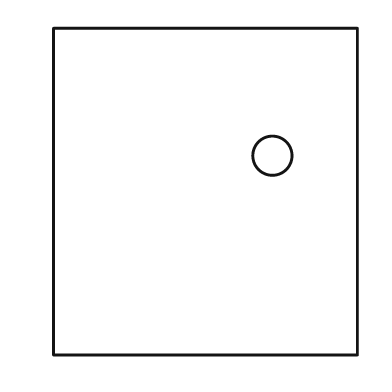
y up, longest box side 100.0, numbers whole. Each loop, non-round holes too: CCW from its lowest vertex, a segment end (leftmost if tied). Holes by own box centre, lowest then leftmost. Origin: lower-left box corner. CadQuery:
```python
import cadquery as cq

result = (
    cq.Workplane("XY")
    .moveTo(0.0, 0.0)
    .lineTo(93.0, 0.0)
    .lineTo(93.0, 100.0)
    .lineTo(0.0, 100.0)
    .close()
    .moveTo(67.0, 61.0)
    .circle(6.0)
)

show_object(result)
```